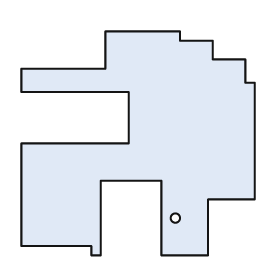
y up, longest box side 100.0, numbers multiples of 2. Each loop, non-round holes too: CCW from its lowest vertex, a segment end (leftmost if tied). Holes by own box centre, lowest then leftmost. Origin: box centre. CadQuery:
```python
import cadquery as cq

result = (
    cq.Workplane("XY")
    .moveTo(-20.0, -48.0)
    .lineTo(-16.0, -48.0)
    .lineTo(-16.0, -16.0)
    .lineTo(10.0, -16.0)
    .lineTo(10.0, -48.0)
    .lineTo(30.0, -48.0)
    .lineTo(30.0, -24.0)
    .lineTo(50.0, -24.0)
    .lineTo(50.0, 26.0)
    .lineTo(46.0, 26.0)
    .lineTo(46.0, 36.0)
    .lineTo(32.0, 36.0)
    .lineTo(32.0, 44.0)
    .lineTo(18.0, 44.0)
    .lineTo(18.0, 48.0)
    .lineTo(-14.0, 48.0)
    .lineTo(-14.0, 32.0)
    .lineTo(-50.0, 32.0)
    .lineTo(-50.0, 22.0)
    .lineTo(-4.0, 22.0)
    .lineTo(-4.0, 0.0)
    .lineTo(-50.0, 0.0)
    .lineTo(-50.0, -44.0)
    .lineTo(-20.0, -44.0)
    .close()
    .moveTo(16.0, -32.0)
    .circle(2.0)
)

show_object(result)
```